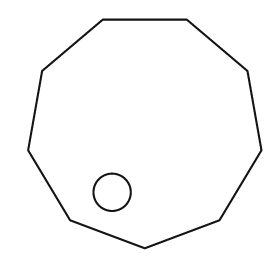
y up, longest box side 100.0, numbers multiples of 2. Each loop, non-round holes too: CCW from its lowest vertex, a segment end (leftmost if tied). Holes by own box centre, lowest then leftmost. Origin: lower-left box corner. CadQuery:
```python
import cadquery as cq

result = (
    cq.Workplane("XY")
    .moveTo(50.0, 0.0)
    .lineTo(82.0, 12.0)
    .lineTo(100.0, 42.0)
    .lineTo(94.0, 76.0)
    .lineTo(68.0, 98.0)
    .lineTo(32.0, 98.0)
    .lineTo(6.0, 76.0)
    .lineTo(0.0, 42.0)
    .lineTo(18.0, 12.0)
    .close()
    .moveTo(36.0, 24.0)
    .circle(8.0)
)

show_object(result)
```